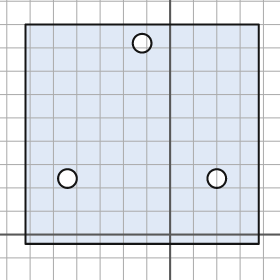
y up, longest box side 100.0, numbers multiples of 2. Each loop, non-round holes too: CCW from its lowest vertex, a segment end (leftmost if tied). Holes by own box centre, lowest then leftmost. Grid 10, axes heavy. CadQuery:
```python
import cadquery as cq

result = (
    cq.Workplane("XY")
    .moveTo(-62.0, -4.0)
    .lineTo(38.0, -4.0)
    .lineTo(38.0, 90.0)
    .lineTo(-62.0, 90.0)
    .close()
    .moveTo(-44.0, 24.0)
    .circle(4.0)
    .moveTo(20.0, 24.0)
    .circle(4.0)
    .moveTo(-12.0, 82.0)
    .circle(4.0)
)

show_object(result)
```